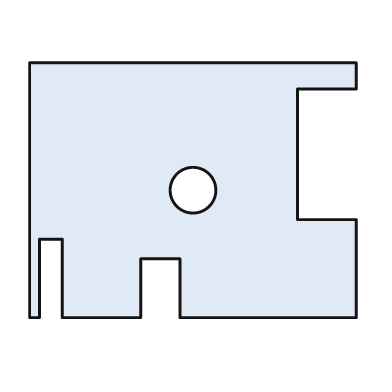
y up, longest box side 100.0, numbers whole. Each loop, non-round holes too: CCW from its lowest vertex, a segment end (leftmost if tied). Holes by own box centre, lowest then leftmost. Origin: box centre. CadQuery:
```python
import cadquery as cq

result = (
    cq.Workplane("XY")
    .moveTo(-50.0, -39.0)
    .lineTo(-47.0, -39.0)
    .lineTo(-47.0, -15.0)
    .lineTo(-40.0, -15.0)
    .lineTo(-40.0, -39.0)
    .lineTo(-16.0, -39.0)
    .lineTo(-16.0, -21.0)
    .lineTo(-4.0, -21.0)
    .lineTo(-4.0, -39.0)
    .lineTo(50.0, -39.0)
    .lineTo(50.0, -9.0)
    .lineTo(32.0, -9.0)
    .lineTo(32.0, 31.0)
    .lineTo(50.0, 31.0)
    .lineTo(50.0, 39.0)
    .lineTo(-50.0, 39.0)
    .close()
    .moveTo(0.0, 0.0)
    .circle(7.0)
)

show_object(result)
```